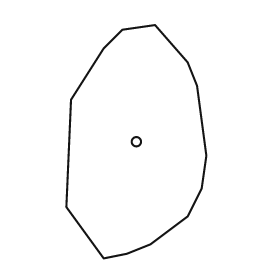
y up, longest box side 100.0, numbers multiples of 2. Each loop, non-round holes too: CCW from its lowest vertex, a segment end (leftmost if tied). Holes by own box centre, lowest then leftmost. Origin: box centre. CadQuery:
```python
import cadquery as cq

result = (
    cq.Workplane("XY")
    .moveTo(-14.0, -50.0)
    .lineTo(-4.0, -48.0)
    .lineTo(6.0, -44.0)
    .lineTo(22.0, -32.0)
    .lineTo(28.0, -20.0)
    .lineTo(30.0, -6.0)
    .lineTo(26.0, 24.0)
    .lineTo(22.0, 34.0)
    .lineTo(8.0, 50.0)
    .lineTo(-6.0, 48.0)
    .lineTo(-14.0, 40.0)
    .lineTo(-28.0, 18.0)
    .lineTo(-30.0, -28.0)
    .close()
    .moveTo(0.0, 0.0)
    .circle(2.0)
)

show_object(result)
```